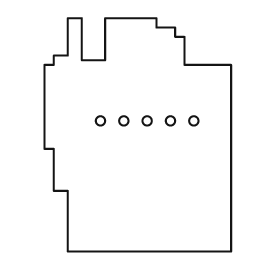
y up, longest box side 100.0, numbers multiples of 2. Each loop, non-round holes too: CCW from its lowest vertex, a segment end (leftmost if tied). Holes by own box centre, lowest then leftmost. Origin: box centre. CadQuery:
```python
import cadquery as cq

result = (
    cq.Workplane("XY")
    .moveTo(-30.0, -50.0)
    .lineTo(40.0, -50.0)
    .lineTo(40.0, 30.0)
    .lineTo(20.0, 30.0)
    .lineTo(20.0, 42.0)
    .lineTo(16.0, 42.0)
    .lineTo(16.0, 46.0)
    .lineTo(8.0, 46.0)
    .lineTo(8.0, 50.0)
    .lineTo(-14.0, 50.0)
    .lineTo(-14.0, 32.0)
    .lineTo(-24.0, 32.0)
    .lineTo(-24.0, 50.0)
    .lineTo(-30.0, 50.0)
    .lineTo(-30.0, 34.0)
    .lineTo(-36.0, 34.0)
    .lineTo(-36.0, 30.0)
    .lineTo(-40.0, 30.0)
    .lineTo(-40.0, -6.0)
    .lineTo(-36.0, -6.0)
    .lineTo(-36.0, -24.0)
    .lineTo(-30.0, -24.0)
    .close()
    .moveTo(-16.0, 6.0)
    .circle(2.0)
    .moveTo(-6.0, 6.0)
    .circle(2.0)
    .moveTo(4.0, 6.0)
    .circle(2.0)
    .moveTo(14.0, 6.0)
    .circle(2.0)
    .moveTo(24.0, 6.0)
    .circle(2.0)
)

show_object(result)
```